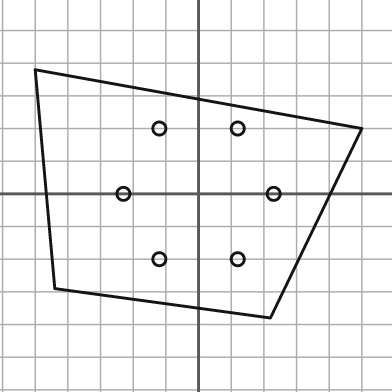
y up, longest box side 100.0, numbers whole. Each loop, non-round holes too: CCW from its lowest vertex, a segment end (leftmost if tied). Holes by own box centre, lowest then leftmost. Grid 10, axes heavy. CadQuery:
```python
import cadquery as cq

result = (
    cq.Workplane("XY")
    .moveTo(22.0, -38.0)
    .lineTo(50.0, 20.0)
    .lineTo(-50.0, 38.0)
    .lineTo(-44.0, -29.0)
    .close()
    .moveTo(-12.0, -20.0)
    .circle(2.0)
    .moveTo(12.0, -20.0)
    .circle(2.0)
    .moveTo(-23.0, 0.0)
    .circle(2.0)
    .moveTo(23.0, 0.0)
    .circle(2.0)
    .moveTo(-12.0, 20.0)
    .circle(2.0)
    .moveTo(12.0, 20.0)
    .circle(2.0)
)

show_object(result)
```